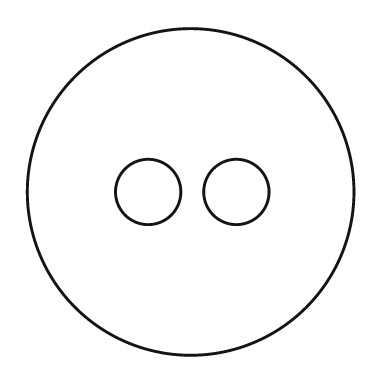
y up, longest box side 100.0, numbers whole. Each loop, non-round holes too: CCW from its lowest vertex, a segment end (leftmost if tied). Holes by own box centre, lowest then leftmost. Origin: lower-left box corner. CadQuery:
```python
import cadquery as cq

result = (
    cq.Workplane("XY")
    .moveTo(50.0, 50.0)
    .circle(50.0)
    .moveTo(37.0, 50.0)
    .circle(10.0)
    .moveTo(64.0, 50.0)
    .circle(10.0)
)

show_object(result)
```